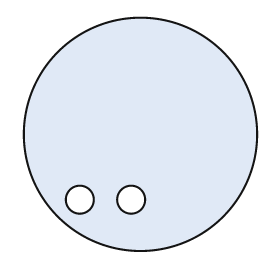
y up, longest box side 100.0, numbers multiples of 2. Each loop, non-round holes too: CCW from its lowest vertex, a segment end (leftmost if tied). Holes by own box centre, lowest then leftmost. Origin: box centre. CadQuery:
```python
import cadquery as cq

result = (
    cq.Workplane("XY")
    .moveTo(0.0, 0.0)
    .circle(50.0)
    .moveTo(-26.0, -28.0)
    .circle(6.0)
    .moveTo(-4.0, -28.0)
    .circle(6.0)
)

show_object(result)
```